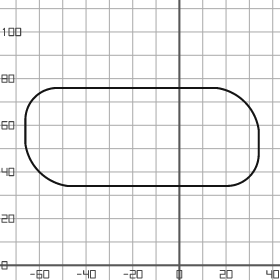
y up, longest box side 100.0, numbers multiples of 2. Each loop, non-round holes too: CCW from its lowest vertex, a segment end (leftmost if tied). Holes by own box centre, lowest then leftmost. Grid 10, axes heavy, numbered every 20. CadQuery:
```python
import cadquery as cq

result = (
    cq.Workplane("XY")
    .moveTo(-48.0, 34.0)
    .lineTo(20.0, 34.0)
    .threePointArc((30.0, 38.0), (34.0, 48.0))
    .lineTo(34.0, 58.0)
    .threePointArc((28.0, 70.0), (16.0, 76.0))
    .lineTo(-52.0, 76.0)
    .threePointArc((-62.0, 72.0), (-66.0, 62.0))
    .lineTo(-66.0, 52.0)
    .threePointArc((-60.0, 40.0), (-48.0, 34.0))
    .close()
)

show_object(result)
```